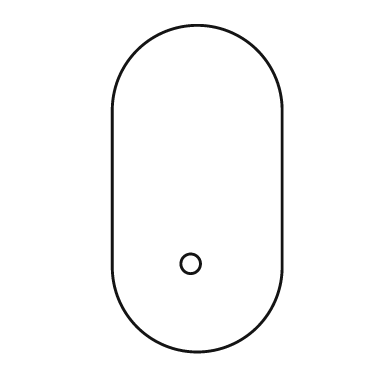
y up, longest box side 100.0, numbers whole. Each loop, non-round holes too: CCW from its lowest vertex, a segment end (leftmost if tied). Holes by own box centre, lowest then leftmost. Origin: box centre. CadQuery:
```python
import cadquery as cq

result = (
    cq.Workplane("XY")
    .moveTo(-26.0, -24.0)
    .threePointArc((0.0, -50.0), (26.0, -24.0))
    .lineTo(26.0, 24.0)
    .threePointArc((0.0, 50.0), (-26.0, 24.0))
    .close()
    .moveTo(-2.0, -23.0)
    .circle(3.0)
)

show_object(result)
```